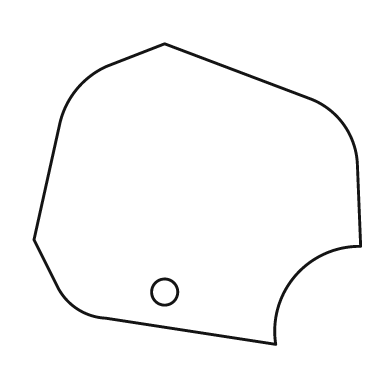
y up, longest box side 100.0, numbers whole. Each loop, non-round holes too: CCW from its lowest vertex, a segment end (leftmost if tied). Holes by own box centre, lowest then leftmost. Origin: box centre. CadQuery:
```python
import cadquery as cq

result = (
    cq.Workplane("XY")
    .moveTo(24.0, -46.0)
    .threePointArc((30.0, -25.0), (50.0, -16.0))
    .lineTo(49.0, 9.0)
    .threePointArc((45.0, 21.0), (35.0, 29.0))
    .lineTo(-10.0, 46.0)
    .lineTo(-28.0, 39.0)
    .threePointArc((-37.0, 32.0), (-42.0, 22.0))
    .lineTo(-50.0, -14.0)
    .lineTo(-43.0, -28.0)
    .threePointArc((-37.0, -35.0), (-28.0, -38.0))
    .close()
    .moveTo(-10.0, -30.0)
    .circle(4.0)
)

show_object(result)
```